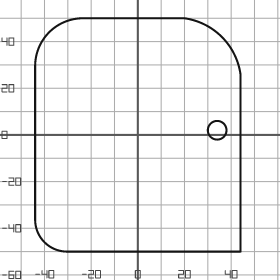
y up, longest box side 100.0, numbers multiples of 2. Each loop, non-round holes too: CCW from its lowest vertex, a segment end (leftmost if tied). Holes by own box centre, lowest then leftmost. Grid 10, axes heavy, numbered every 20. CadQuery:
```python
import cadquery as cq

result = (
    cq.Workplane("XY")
    .moveTo(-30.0, -50.0)
    .lineTo(44.0, -50.0)
    .lineTo(44.0, 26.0)
    .threePointArc((36.0, 42.0), (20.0, 50.0))
    .lineTo(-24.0, 50.0)
    .threePointArc((-38.0, 44.0), (-44.0, 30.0))
    .lineTo(-44.0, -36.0)
    .threePointArc((-40.0, -46.0), (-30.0, -50.0))
    .close()
    .moveTo(34.0, 2.0)
    .circle(4.0)
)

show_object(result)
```